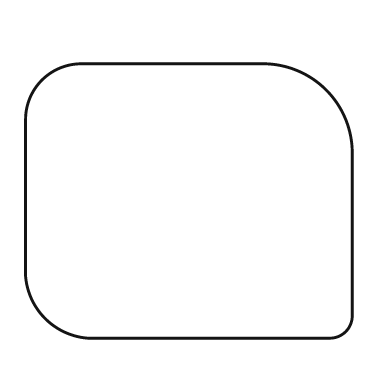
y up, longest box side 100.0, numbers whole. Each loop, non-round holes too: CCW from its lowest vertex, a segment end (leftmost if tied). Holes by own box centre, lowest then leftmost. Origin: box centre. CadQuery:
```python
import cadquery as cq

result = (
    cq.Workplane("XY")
    .moveTo(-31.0, -42.0)
    .lineTo(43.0, -42.0)
    .threePointArc((48.0, -40.0), (50.0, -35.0))
    .lineTo(50.0, 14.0)
    .threePointArc((42.0, 34.0), (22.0, 42.0))
    .lineTo(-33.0, 42.0)
    .threePointArc((-45.0, 37.0), (-50.0, 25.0))
    .lineTo(-50.0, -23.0)
    .threePointArc((-44.0, -36.0), (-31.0, -42.0))
    .close()
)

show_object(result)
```